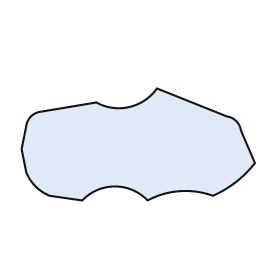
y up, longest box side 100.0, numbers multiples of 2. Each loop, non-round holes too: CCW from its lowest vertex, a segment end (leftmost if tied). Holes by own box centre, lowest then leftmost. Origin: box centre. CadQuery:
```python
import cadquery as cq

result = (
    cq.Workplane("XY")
    .moveTo(-24.0, -24.0)
    .threePointArc((-10.0, -18.0), (4.0, -24.0))
    .threePointArc((18.0, -20.0), (32.0, -22.0))
    .threePointArc((42.0, -16.0), (50.0, -8.0))
    .lineTo(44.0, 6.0)
    .threePointArc((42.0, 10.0), (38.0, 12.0))
    .lineTo(8.0, 24.0)
    .threePointArc((-4.0, 16.0), (-18.0, 18.0))
    .lineTo(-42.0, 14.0)
    .threePointArc((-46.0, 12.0), (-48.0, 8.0))
    .lineTo(-50.0, -2.0)
    .lineTo(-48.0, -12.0)
    .threePointArc((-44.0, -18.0), (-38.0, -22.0))
    .close()
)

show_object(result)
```